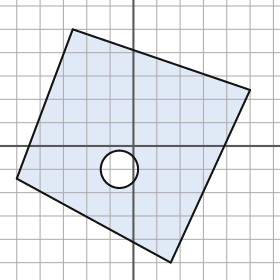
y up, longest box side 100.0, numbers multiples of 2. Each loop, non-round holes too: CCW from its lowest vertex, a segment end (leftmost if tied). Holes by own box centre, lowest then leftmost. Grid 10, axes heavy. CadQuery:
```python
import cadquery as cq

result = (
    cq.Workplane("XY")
    .moveTo(16.0, -50.0)
    .lineTo(50.0, 24.0)
    .lineTo(-26.0, 50.0)
    .lineTo(-50.0, -14.0)
    .close()
    .moveTo(-6.0, -10.0)
    .circle(8.0)
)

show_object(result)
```